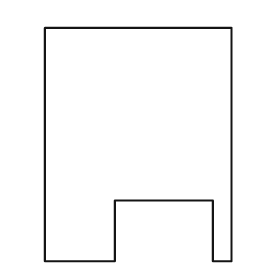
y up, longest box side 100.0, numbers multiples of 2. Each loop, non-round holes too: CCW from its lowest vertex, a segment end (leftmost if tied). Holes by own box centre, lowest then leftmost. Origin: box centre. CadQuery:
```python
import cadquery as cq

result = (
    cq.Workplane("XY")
    .moveTo(-40.0, -50.0)
    .lineTo(-10.0, -50.0)
    .lineTo(-10.0, -24.0)
    .lineTo(32.0, -24.0)
    .lineTo(32.0, -50.0)
    .lineTo(40.0, -50.0)
    .lineTo(40.0, 50.0)
    .lineTo(-40.0, 50.0)
    .close()
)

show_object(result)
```